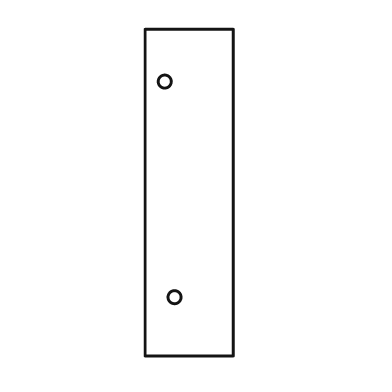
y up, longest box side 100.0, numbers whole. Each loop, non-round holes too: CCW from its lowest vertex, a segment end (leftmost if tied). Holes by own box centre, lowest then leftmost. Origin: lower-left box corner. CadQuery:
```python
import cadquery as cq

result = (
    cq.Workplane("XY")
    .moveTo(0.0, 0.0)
    .lineTo(27.0, 0.0)
    .lineTo(27.0, 100.0)
    .lineTo(0.0, 100.0)
    .close()
    .moveTo(9.0, 18.0)
    .circle(2.0)
    .moveTo(6.0, 84.0)
    .circle(2.0)
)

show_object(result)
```